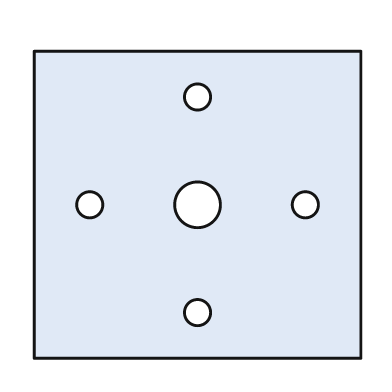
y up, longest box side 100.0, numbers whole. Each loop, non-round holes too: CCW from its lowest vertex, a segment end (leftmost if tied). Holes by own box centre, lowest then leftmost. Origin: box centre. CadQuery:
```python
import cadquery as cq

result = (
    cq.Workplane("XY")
    .moveTo(-50.0, -47.0)
    .lineTo(50.0, -47.0)
    .lineTo(50.0, 47.0)
    .lineTo(-50.0, 47.0)
    .close()
    .moveTo(0.0, -33.0)
    .circle(4.0)
    .moveTo(-33.0, 0.0)
    .circle(4.0)
    .moveTo(0.0, 0.0)
    .circle(7.0)
    .moveTo(33.0, 0.0)
    .circle(4.0)
    .moveTo(0.0, 33.0)
    .circle(4.0)
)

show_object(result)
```